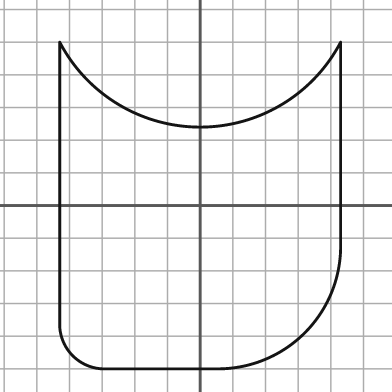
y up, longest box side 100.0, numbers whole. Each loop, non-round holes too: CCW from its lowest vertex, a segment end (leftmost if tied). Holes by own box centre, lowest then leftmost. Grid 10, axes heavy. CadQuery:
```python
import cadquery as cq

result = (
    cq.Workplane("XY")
    .moveTo(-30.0, -50.0)
    .lineTo(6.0, -50.0)
    .threePointArc((32.0, -39.0), (43.0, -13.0))
    .lineTo(43.0, 50.0)
    .threePointArc((0.0, 24.0), (-43.0, 50.0))
    .lineTo(-43.0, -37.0)
    .threePointArc((-39.0, -46.0), (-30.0, -50.0))
    .close()
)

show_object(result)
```